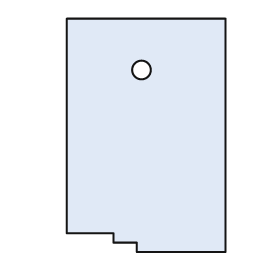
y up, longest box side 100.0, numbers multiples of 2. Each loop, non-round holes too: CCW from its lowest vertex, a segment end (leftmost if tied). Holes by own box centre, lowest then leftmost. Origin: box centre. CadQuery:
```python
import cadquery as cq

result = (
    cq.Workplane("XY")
    .moveTo(-4.0, -50.0)
    .lineTo(34.0, -50.0)
    .lineTo(34.0, 50.0)
    .lineTo(-34.0, 50.0)
    .lineTo(-34.0, -42.0)
    .lineTo(-14.0, -42.0)
    .lineTo(-14.0, -46.0)
    .lineTo(-4.0, -46.0)
    .close()
    .moveTo(-2.0, 28.0)
    .circle(4.0)
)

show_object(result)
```